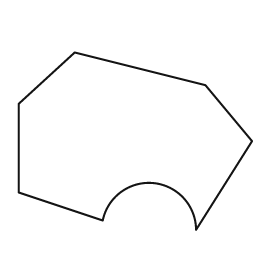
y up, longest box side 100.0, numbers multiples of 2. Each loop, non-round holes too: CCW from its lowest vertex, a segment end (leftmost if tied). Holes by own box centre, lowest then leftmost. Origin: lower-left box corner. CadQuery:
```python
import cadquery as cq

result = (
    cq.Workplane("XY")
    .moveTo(76.0, 0.0)
    .lineTo(100.0, 38.0)
    .lineTo(80.0, 62.0)
    .lineTo(24.0, 76.0)
    .lineTo(0.0, 54.0)
    .lineTo(0.0, 16.0)
    .lineTo(36.0, 4.0)
    .threePointArc((58.0, 20.0), (76.0, 0.0))
    .close()
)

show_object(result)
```